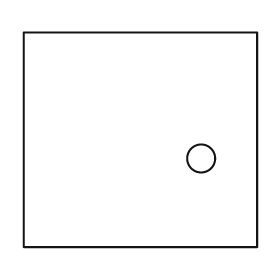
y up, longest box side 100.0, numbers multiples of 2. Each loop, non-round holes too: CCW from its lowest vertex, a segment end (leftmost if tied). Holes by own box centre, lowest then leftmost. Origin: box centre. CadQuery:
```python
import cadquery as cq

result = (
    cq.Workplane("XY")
    .moveTo(-50.0, -46.0)
    .lineTo(50.0, -46.0)
    .lineTo(50.0, 46.0)
    .lineTo(-50.0, 46.0)
    .close()
    .moveTo(26.0, -8.0)
    .circle(6.0)
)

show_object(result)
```